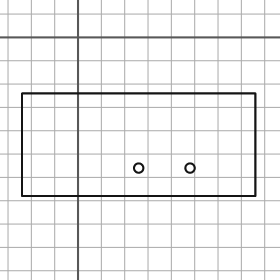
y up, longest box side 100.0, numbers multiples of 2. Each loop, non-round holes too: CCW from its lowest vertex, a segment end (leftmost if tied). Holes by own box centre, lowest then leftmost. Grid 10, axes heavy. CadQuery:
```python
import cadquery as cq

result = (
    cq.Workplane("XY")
    .moveTo(-24.0, -68.0)
    .lineTo(76.0, -68.0)
    .lineTo(76.0, -24.0)
    .lineTo(-24.0, -24.0)
    .close()
    .moveTo(26.0, -56.0)
    .circle(2.0)
    .moveTo(48.0, -56.0)
    .circle(2.0)
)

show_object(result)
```